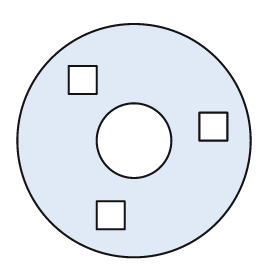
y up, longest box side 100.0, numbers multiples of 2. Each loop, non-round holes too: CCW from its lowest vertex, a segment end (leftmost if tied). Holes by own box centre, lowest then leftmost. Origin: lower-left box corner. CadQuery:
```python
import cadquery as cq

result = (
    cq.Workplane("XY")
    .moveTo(50.0, 50.0)
    .circle(50.0)
    .moveTo(34.0, 12.0)
    .lineTo(46.0, 12.0)
    .lineTo(46.0, 24.0)
    .lineTo(34.0, 24.0)
    .close()
    .moveTo(50.0, 50.0)
    .circle(16.0)
    .moveTo(78.0, 50.0)
    .lineTo(90.0, 50.0)
    .lineTo(90.0, 62.0)
    .lineTo(78.0, 62.0)
    .close()
    .moveTo(22.0, 70.0)
    .lineTo(34.0, 70.0)
    .lineTo(34.0, 82.0)
    .lineTo(22.0, 82.0)
    .close()
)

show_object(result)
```